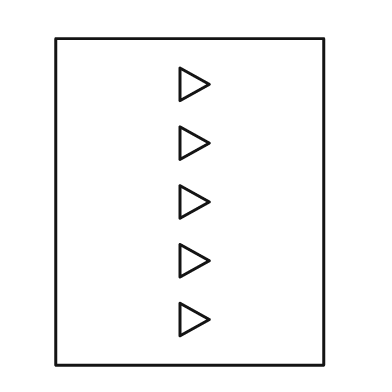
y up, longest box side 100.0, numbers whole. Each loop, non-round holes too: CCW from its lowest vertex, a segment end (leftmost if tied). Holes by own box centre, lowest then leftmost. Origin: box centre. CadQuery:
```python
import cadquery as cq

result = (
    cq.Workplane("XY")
    .moveTo(-41.0, -50.0)
    .lineTo(41.0, -50.0)
    .lineTo(41.0, 50.0)
    .lineTo(-41.0, 50.0)
    .close()
    .moveTo(-3.0, -41.0)
    .lineTo(6.0, -36.0)
    .lineTo(-3.0, -31.0)
    .close()
    .moveTo(-3.0, -23.0)
    .lineTo(6.0, -18.0)
    .lineTo(-3.0, -13.0)
    .close()
    .moveTo(-3.0, -5.0)
    .lineTo(6.0, 0.0)
    .lineTo(-3.0, 5.0)
    .close()
    .moveTo(-3.0, 13.0)
    .lineTo(6.0, 18.0)
    .lineTo(-3.0, 23.0)
    .close()
    .moveTo(-3.0, 31.0)
    .lineTo(6.0, 36.0)
    .lineTo(-3.0, 41.0)
    .close()
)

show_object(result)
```